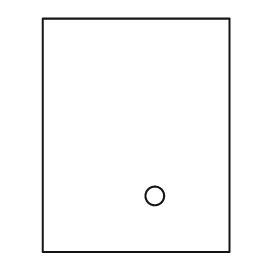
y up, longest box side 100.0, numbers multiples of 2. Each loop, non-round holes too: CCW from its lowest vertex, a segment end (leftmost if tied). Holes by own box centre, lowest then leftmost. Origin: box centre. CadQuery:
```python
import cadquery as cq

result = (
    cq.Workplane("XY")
    .moveTo(-40.0, -50.0)
    .lineTo(40.0, -50.0)
    .lineTo(40.0, 50.0)
    .lineTo(-40.0, 50.0)
    .close()
    .moveTo(8.0, -26.0)
    .circle(4.0)
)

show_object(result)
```